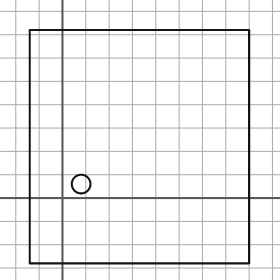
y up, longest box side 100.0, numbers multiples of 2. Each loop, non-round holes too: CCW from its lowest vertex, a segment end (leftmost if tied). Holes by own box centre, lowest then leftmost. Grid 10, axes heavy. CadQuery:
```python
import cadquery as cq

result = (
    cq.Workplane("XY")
    .moveTo(-14.0, -28.0)
    .lineTo(80.0, -28.0)
    .lineTo(80.0, 72.0)
    .lineTo(-14.0, 72.0)
    .close()
    .moveTo(8.0, 6.0)
    .circle(4.0)
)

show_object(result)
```